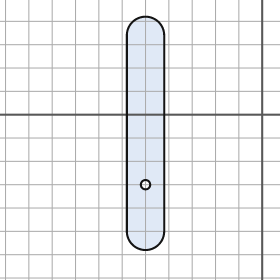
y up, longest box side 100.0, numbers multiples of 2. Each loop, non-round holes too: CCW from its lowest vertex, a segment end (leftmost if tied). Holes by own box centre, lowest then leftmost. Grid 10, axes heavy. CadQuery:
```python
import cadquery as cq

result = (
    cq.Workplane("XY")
    .moveTo(-58.0, -50.0)
    .threePointArc((-50.0, -58.0), (-42.0, -50.0))
    .lineTo(-42.0, 34.0)
    .threePointArc((-50.0, 42.0), (-58.0, 34.0))
    .close()
    .moveTo(-50.0, -30.0)
    .circle(2.0)
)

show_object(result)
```